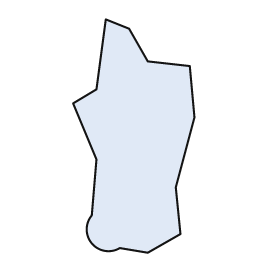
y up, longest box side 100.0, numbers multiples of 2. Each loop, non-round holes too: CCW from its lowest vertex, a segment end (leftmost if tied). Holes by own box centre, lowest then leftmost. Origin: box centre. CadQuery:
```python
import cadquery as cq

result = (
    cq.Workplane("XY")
    .moveTo(6.0, -50.0)
    .lineTo(20.0, -42.0)
    .lineTo(18.0, -22.0)
    .lineTo(26.0, 8.0)
    .lineTo(24.0, 30.0)
    .lineTo(6.0, 32.0)
    .lineTo(-2.0, 46.0)
    .lineTo(-12.0, 50.0)
    .lineTo(-16.0, 20.0)
    .lineTo(-26.0, 14.0)
    .lineTo(-16.0, -10.0)
    .lineTo(-18.0, -34.0)
    .threePointArc((-18.0, -46.0), (-6.0, -48.0))
    .close()
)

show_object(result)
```